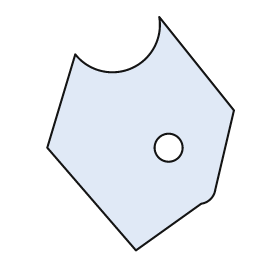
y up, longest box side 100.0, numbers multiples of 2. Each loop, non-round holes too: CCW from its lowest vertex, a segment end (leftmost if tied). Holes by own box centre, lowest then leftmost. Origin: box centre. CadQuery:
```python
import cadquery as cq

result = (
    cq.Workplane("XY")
    .moveTo(-2.0, -50.0)
    .lineTo(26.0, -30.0)
    .threePointArc((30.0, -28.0), (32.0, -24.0))
    .lineTo(40.0, 10.0)
    .lineTo(8.0, 50.0)
    .threePointArc((-4.0, 28.0), (-28.0, 34.0))
    .lineTo(-40.0, -6.0)
    .close()
    .moveTo(12.0, -6.0)
    .circle(6.0)
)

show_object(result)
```